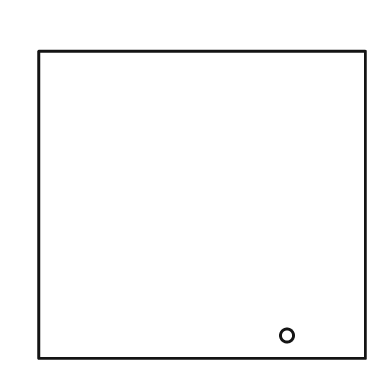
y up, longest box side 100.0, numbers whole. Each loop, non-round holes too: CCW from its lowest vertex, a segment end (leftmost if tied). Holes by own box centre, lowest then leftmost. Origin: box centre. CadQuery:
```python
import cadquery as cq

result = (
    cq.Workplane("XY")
    .moveTo(-50.0, -47.0)
    .lineTo(50.0, -47.0)
    .lineTo(50.0, 47.0)
    .lineTo(-50.0, 47.0)
    .close()
    .moveTo(26.0, -40.0)
    .circle(2.0)
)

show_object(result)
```